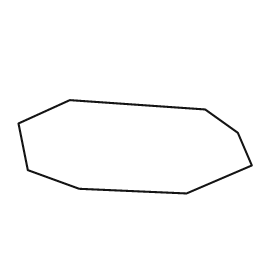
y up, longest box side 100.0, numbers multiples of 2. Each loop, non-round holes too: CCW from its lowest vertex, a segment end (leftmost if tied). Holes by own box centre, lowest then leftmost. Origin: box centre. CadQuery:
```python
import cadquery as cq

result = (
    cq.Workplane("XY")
    .moveTo(22.0, -20.0)
    .lineTo(50.0, -8.0)
    .lineTo(44.0, 6.0)
    .lineTo(30.0, 16.0)
    .lineTo(-28.0, 20.0)
    .lineTo(-50.0, 10.0)
    .lineTo(-46.0, -10.0)
    .lineTo(-24.0, -18.0)
    .close()
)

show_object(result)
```